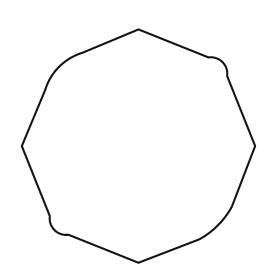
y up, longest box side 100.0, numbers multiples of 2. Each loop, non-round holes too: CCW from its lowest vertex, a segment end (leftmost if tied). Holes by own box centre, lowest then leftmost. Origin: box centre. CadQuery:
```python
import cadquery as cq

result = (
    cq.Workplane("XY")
    .moveTo(0.0, -50.0)
    .lineTo(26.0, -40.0)
    .threePointArc((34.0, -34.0), (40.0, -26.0))
    .lineTo(50.0, 0.0)
    .lineTo(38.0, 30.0)
    .threePointArc((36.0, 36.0), (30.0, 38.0))
    .lineTo(0.0, 50.0)
    .lineTo(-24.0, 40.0)
    .threePointArc((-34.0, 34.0), (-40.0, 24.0))
    .lineTo(-50.0, 0.0)
    .lineTo(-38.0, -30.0)
    .threePointArc((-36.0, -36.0), (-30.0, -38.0))
    .close()
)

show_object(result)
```